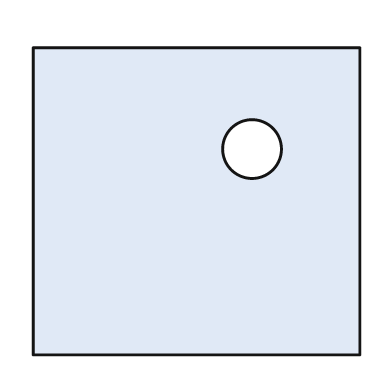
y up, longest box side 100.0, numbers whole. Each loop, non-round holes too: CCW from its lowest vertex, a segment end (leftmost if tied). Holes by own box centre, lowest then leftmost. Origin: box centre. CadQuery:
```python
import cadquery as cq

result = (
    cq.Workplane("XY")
    .moveTo(-50.0, -47.0)
    .lineTo(50.0, -47.0)
    .lineTo(50.0, 47.0)
    .lineTo(-50.0, 47.0)
    .close()
    .moveTo(17.0, 16.0)
    .circle(9.0)
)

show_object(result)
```